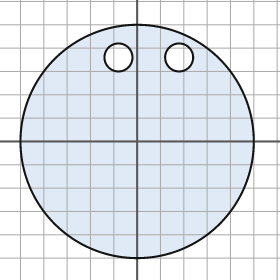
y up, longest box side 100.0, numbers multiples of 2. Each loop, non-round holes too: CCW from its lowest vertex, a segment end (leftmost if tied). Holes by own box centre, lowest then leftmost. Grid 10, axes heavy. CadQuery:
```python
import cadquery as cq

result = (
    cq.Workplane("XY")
    .moveTo(0.0, 0.0)
    .circle(50.0)
    .moveTo(-8.0, 36.0)
    .circle(6.0)
    .moveTo(18.0, 36.0)
    .circle(6.0)
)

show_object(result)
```